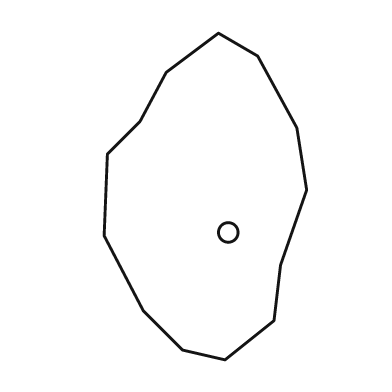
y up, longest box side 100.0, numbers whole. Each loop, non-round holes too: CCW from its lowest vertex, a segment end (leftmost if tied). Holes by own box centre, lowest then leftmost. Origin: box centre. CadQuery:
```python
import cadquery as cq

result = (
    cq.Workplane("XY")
    .moveTo(6.0, -50.0)
    .lineTo(21.0, -38.0)
    .lineTo(23.0, -21.0)
    .lineTo(31.0, 2.0)
    .lineTo(28.0, 21.0)
    .lineTo(16.0, 43.0)
    .lineTo(4.0, 50.0)
    .lineTo(-12.0, 38.0)
    .lineTo(-20.0, 23.0)
    .lineTo(-30.0, 13.0)
    .lineTo(-31.0, -12.0)
    .lineTo(-19.0, -35.0)
    .lineTo(-7.0, -47.0)
    .close()
    .moveTo(7.0, -11.0)
    .circle(3.0)
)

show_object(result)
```